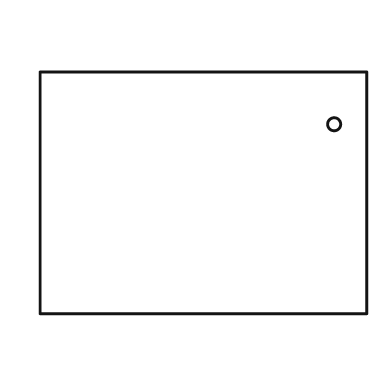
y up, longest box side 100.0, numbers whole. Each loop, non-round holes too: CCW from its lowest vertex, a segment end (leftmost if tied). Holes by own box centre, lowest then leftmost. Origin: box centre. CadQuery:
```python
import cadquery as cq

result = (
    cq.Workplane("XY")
    .moveTo(-50.0, -37.0)
    .lineTo(50.0, -37.0)
    .lineTo(50.0, 37.0)
    .lineTo(-50.0, 37.0)
    .close()
    .moveTo(40.0, 21.0)
    .circle(2.0)
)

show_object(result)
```